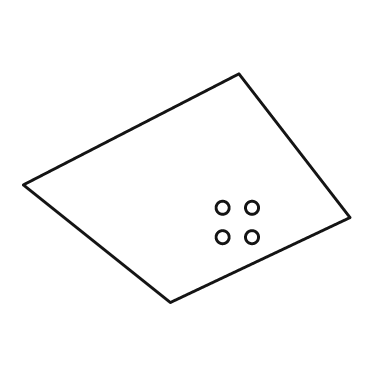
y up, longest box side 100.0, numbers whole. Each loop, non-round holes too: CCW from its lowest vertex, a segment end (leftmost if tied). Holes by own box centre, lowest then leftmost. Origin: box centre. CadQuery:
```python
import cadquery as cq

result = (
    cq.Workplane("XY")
    .moveTo(-5.0, -35.0)
    .lineTo(50.0, -9.0)
    .lineTo(16.0, 35.0)
    .lineTo(-50.0, 1.0)
    .close()
    .moveTo(11.0, -15.0)
    .circle(2.0)
    .moveTo(20.0, -15.0)
    .circle(2.0)
    .moveTo(11.0, -6.0)
    .circle(2.0)
    .moveTo(20.0, -6.0)
    .circle(2.0)
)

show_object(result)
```